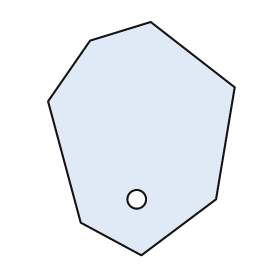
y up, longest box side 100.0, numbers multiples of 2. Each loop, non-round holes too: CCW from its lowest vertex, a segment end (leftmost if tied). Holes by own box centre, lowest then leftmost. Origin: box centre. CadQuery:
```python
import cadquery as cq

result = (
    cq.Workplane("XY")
    .moveTo(0.0, -50.0)
    .lineTo(32.0, -26.0)
    .lineTo(40.0, 22.0)
    .lineTo(4.0, 50.0)
    .lineTo(-22.0, 42.0)
    .lineTo(-40.0, 16.0)
    .lineTo(-26.0, -36.0)
    .close()
    .moveTo(-2.0, -26.0)
    .circle(4.0)
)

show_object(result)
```